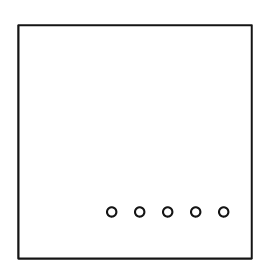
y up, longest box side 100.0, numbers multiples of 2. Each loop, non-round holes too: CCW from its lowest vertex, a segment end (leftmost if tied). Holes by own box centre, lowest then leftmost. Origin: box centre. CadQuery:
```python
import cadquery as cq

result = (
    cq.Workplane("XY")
    .moveTo(-50.0, -50.0)
    .lineTo(50.0, -50.0)
    .lineTo(50.0, 50.0)
    .lineTo(-50.0, 50.0)
    .close()
    .moveTo(-10.0, -30.0)
    .circle(2.0)
    .moveTo(2.0, -30.0)
    .circle(2.0)
    .moveTo(14.0, -30.0)
    .circle(2.0)
    .moveTo(26.0, -30.0)
    .circle(2.0)
    .moveTo(38.0, -30.0)
    .circle(2.0)
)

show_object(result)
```